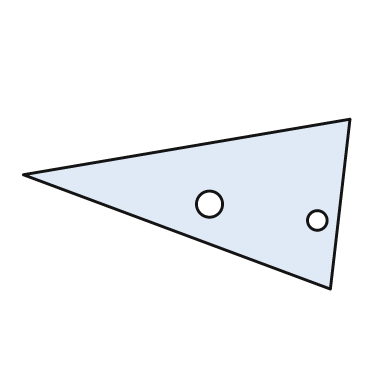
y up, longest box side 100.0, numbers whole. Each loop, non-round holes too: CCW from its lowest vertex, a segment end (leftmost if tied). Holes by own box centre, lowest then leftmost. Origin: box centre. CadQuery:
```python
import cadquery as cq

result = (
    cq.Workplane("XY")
    .moveTo(44.0, -26.0)
    .lineTo(50.0, 26.0)
    .lineTo(-50.0, 9.0)
    .close()
    .moveTo(40.0, -5.0)
    .circle(3.0)
    .moveTo(7.0, 0.0)
    .circle(4.0)
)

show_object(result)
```